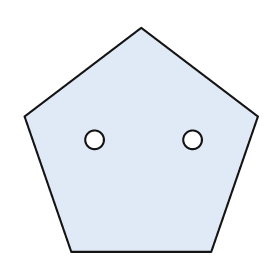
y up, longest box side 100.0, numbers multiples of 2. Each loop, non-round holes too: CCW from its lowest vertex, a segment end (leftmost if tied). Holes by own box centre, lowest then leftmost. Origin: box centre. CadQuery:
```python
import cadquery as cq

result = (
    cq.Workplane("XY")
    .moveTo(-30.0, -48.0)
    .lineTo(30.0, -48.0)
    .lineTo(50.0, 10.0)
    .lineTo(0.0, 48.0)
    .lineTo(-50.0, 10.0)
    .close()
    .moveTo(-20.0, 0.0)
    .circle(4.0)
    .moveTo(22.0, 0.0)
    .circle(4.0)
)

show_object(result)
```